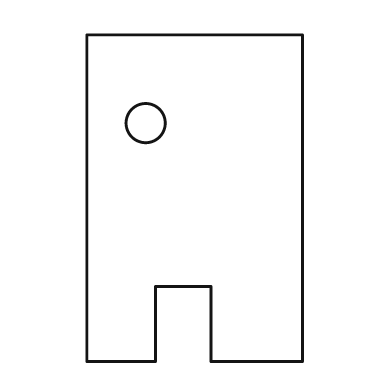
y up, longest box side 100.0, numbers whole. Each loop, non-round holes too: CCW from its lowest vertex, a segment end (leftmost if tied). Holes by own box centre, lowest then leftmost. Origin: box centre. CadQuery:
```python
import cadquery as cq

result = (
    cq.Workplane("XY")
    .moveTo(-33.0, -50.0)
    .lineTo(-12.0, -50.0)
    .lineTo(-12.0, -27.0)
    .lineTo(5.0, -27.0)
    .lineTo(5.0, -50.0)
    .lineTo(33.0, -50.0)
    .lineTo(33.0, 50.0)
    .lineTo(-33.0, 50.0)
    .close()
    .moveTo(-15.0, 23.0)
    .circle(6.0)
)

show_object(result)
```